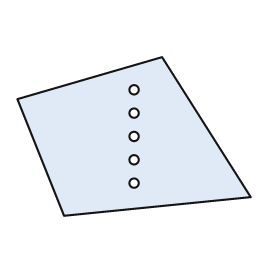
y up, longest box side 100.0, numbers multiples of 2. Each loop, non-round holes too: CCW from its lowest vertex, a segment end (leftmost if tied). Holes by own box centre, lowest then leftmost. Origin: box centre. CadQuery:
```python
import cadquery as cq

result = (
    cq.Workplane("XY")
    .moveTo(-30.0, -34.0)
    .lineTo(50.0, -26.0)
    .lineTo(12.0, 34.0)
    .lineTo(-50.0, 16.0)
    .close()
    .moveTo(0.0, -20.0)
    .circle(2.0)
    .moveTo(0.0, -10.0)
    .circle(2.0)
    .moveTo(0.0, 0.0)
    .circle(2.0)
    .moveTo(0.0, 10.0)
    .circle(2.0)
    .moveTo(0.0, 20.0)
    .circle(2.0)
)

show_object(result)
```